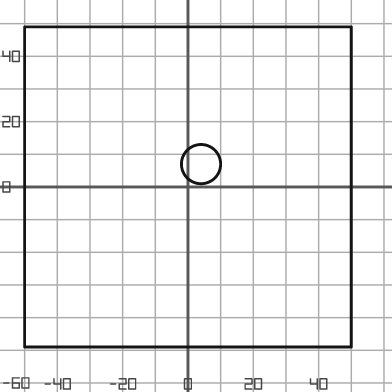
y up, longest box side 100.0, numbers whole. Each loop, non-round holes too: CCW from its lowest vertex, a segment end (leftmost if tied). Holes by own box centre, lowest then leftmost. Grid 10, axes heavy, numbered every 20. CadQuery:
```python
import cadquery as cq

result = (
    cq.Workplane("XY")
    .moveTo(-50.0, -49.0)
    .lineTo(50.0, -49.0)
    .lineTo(50.0, 49.0)
    .lineTo(-50.0, 49.0)
    .close()
    .moveTo(4.0, 7.0)
    .circle(6.0)
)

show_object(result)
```